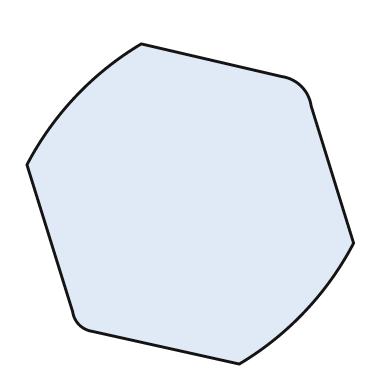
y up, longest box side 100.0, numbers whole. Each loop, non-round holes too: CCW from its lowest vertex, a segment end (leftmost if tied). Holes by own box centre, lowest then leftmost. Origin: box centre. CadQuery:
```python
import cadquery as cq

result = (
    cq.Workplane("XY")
    .moveTo(15.0, -49.0)
    .threePointArc((35.0, -33.0), (50.0, -12.0))
    .lineTo(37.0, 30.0)
    .threePointArc((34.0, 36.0), (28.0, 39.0))
    .lineTo(-15.0, 49.0)
    .threePointArc((-35.0, 33.0), (-50.0, 12.0))
    .lineTo(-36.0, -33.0)
    .threePointArc((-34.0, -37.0), (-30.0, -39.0))
    .close()
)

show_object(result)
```